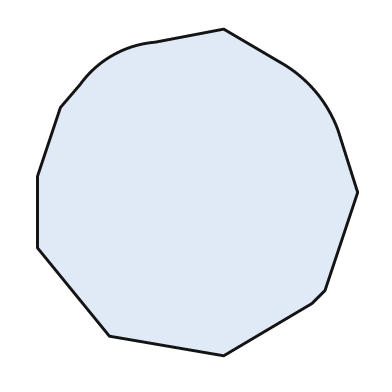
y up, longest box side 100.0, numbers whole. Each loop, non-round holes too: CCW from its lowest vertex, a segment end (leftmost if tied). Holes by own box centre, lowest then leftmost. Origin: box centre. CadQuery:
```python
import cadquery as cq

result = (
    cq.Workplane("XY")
    .moveTo(8.0, -50.0)
    .lineTo(35.0, -34.0)
    .lineTo(39.0, -30.0)
    .lineTo(49.0, 0.0)
    .lineTo(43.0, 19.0)
    .threePointArc((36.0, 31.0), (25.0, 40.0))
    .lineTo(8.0, 50.0)
    .lineTo(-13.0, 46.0)
    .threePointArc((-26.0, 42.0), (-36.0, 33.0))
    .lineTo(-42.0, 26.0)
    .lineTo(-49.0, 5.0)
    .lineTo(-49.0, -17.0)
    .lineTo(-27.0, -44.0)
    .close()
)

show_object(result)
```